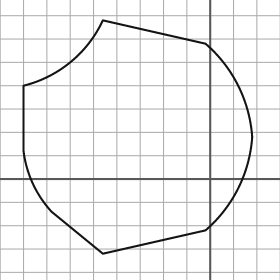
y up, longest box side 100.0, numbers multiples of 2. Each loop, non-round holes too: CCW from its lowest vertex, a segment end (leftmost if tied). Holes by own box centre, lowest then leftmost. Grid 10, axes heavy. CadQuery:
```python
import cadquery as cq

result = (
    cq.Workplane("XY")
    .moveTo(-46.0, -32.0)
    .lineTo(-2.0, -22.0)
    .threePointArc((12.0, -4.0), (18.0, 18.0))
    .threePointArc((12.0, 40.0), (-2.0, 58.0))
    .lineTo(-46.0, 68.0)
    .threePointArc((-60.0, 50.0), (-80.0, 40.0))
    .lineTo(-80.0, 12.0)
    .threePointArc((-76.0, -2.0), (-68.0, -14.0))
    .close()
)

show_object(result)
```